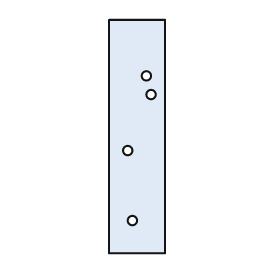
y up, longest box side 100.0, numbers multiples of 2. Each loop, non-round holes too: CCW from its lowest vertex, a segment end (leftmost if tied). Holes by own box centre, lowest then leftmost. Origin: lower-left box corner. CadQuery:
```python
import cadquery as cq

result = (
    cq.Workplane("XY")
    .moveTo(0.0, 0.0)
    .lineTo(24.0, 0.0)
    .lineTo(24.0, 100.0)
    .lineTo(0.0, 100.0)
    .close()
    .moveTo(10.0, 14.0)
    .circle(2.0)
    .moveTo(8.0, 44.0)
    .circle(2.0)
    .moveTo(18.0, 68.0)
    .circle(2.0)
    .moveTo(16.0, 76.0)
    .circle(2.0)
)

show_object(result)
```